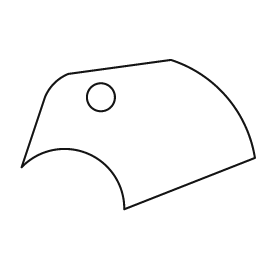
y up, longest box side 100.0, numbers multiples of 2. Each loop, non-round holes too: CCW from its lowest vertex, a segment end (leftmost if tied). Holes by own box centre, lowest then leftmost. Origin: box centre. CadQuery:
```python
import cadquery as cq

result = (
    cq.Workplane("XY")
    .moveTo(-6.0, -32.0)
    .lineTo(50.0, -10.0)
    .threePointArc((38.0, 16.0), (14.0, 32.0))
    .lineTo(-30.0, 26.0)
    .threePointArc((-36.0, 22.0), (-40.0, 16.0))
    .lineTo(-50.0, -14.0)
    .threePointArc((-22.0, -8.0), (-6.0, -32.0))
    .close()
    .moveTo(-16.0, 16.0)
    .circle(6.0)
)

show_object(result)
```